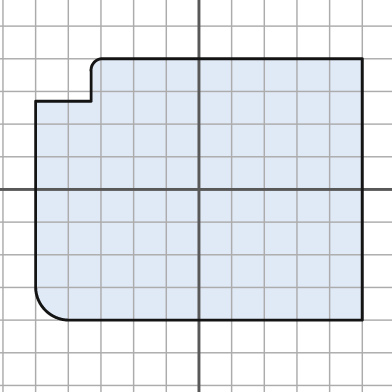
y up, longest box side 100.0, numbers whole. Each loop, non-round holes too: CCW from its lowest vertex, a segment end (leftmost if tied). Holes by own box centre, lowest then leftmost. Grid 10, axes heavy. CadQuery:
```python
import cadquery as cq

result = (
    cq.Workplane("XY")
    .moveTo(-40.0, -40.0)
    .lineTo(50.0, -40.0)
    .lineTo(50.0, 40.0)
    .lineTo(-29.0, 40.0)
    .threePointArc((-32.0, 39.0), (-33.0, 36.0))
    .lineTo(-33.0, 27.0)
    .lineTo(-50.0, 27.0)
    .lineTo(-50.0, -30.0)
    .threePointArc((-47.0, -37.0), (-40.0, -40.0))
    .close()
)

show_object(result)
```